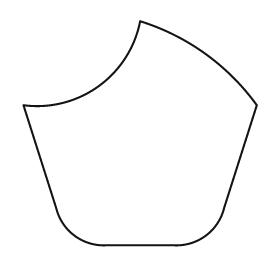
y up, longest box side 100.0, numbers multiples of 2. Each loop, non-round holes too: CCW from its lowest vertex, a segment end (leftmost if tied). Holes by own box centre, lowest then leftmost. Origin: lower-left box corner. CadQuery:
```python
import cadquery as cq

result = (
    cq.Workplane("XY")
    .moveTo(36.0, 0.0)
    .lineTo(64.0, 0.0)
    .threePointArc((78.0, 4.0), (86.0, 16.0))
    .lineTo(100.0, 60.0)
    .threePointArc((78.0, 82.0), (50.0, 96.0))
    .threePointArc((32.0, 68.0), (0.0, 60.0))
    .lineTo(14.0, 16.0)
    .threePointArc((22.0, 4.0), (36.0, 0.0))
    .close()
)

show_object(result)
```